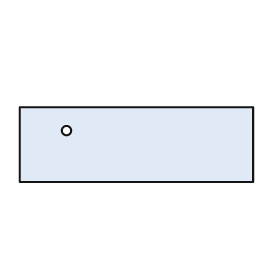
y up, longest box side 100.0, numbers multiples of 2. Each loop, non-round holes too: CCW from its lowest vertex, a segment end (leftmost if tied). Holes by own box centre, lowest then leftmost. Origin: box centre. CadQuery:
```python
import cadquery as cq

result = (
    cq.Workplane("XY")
    .moveTo(-50.0, -16.0)
    .lineTo(50.0, -16.0)
    .lineTo(50.0, 16.0)
    .lineTo(-50.0, 16.0)
    .close()
    .moveTo(-30.0, 6.0)
    .circle(2.0)
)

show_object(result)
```